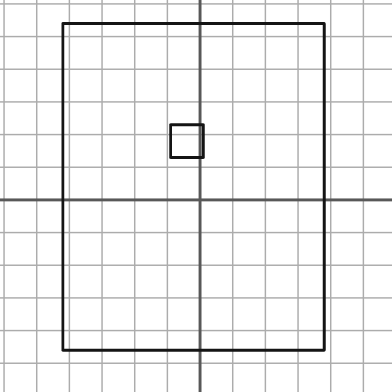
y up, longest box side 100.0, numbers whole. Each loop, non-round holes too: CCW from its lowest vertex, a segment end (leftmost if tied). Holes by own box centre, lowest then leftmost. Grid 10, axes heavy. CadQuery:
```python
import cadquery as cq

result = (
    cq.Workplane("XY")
    .moveTo(-42.0, -46.0)
    .lineTo(38.0, -46.0)
    .lineTo(38.0, 54.0)
    .lineTo(-42.0, 54.0)
    .close()
    .moveTo(-9.0, 13.0)
    .lineTo(1.0, 13.0)
    .lineTo(1.0, 23.0)
    .lineTo(-9.0, 23.0)
    .close()
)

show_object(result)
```